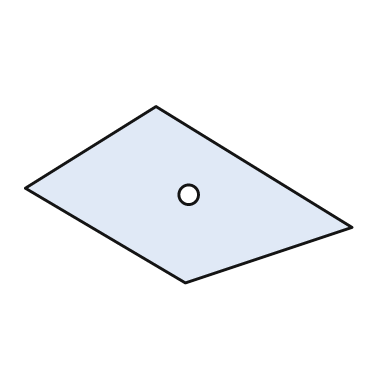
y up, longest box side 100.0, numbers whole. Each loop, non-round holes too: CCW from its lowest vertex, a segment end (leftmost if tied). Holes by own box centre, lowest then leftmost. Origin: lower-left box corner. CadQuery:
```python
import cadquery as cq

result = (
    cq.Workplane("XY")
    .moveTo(49.0, 0.0)
    .lineTo(100.0, 17.0)
    .lineTo(40.0, 54.0)
    .lineTo(0.0, 29.0)
    .close()
    .moveTo(50.0, 27.0)
    .circle(3.0)
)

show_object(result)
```